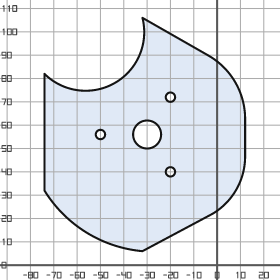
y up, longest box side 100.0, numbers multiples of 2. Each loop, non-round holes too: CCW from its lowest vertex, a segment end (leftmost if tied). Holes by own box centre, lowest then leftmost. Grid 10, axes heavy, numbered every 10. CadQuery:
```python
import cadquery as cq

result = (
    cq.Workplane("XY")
    .moveTo(-32.0, 6.0)
    .lineTo(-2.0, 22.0)
    .threePointArc((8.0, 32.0), (12.0, 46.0))
    .lineTo(12.0, 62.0)
    .threePointArc((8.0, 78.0), (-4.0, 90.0))
    .lineTo(-32.0, 106.0)
    .threePointArc((-44.0, 78.0), (-74.0, 82.0))
    .lineTo(-74.0, 32.0)
    .threePointArc((-56.0, 14.0), (-32.0, 6.0))
    .close()
    .moveTo(-20.0, 40.0)
    .circle(2.0)
    .moveTo(-50.0, 56.0)
    .circle(2.0)
    .moveTo(-30.0, 56.0)
    .circle(6.0)
    .moveTo(-20.0, 72.0)
    .circle(2.0)
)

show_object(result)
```